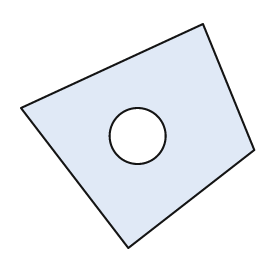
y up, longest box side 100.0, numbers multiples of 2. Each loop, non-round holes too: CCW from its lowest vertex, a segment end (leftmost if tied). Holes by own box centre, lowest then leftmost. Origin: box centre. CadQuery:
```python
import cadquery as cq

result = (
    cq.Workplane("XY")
    .moveTo(-4.0, -48.0)
    .lineTo(50.0, -6.0)
    .lineTo(28.0, 48.0)
    .lineTo(-50.0, 12.0)
    .close()
    .moveTo(0.0, 0.0)
    .circle(12.0)
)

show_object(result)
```